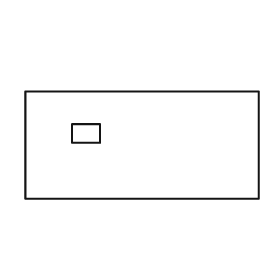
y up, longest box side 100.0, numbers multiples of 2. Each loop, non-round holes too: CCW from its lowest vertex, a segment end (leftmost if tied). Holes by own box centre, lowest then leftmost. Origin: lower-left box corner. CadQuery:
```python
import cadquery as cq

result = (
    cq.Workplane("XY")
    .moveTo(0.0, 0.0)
    .lineTo(100.0, 0.0)
    .lineTo(100.0, 46.0)
    .lineTo(0.0, 46.0)
    .close()
    .moveTo(20.0, 24.0)
    .lineTo(32.0, 24.0)
    .lineTo(32.0, 32.0)
    .lineTo(20.0, 32.0)
    .close()
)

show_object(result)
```